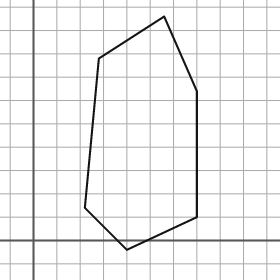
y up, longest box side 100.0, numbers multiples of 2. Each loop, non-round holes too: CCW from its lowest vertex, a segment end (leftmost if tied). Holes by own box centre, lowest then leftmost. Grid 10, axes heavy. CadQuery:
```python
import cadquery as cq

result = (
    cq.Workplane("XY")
    .moveTo(40.0, -4.0)
    .lineTo(70.0, 10.0)
    .lineTo(70.0, 64.0)
    .lineTo(56.0, 96.0)
    .lineTo(28.0, 78.0)
    .lineTo(22.0, 14.0)
    .close()
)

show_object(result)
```